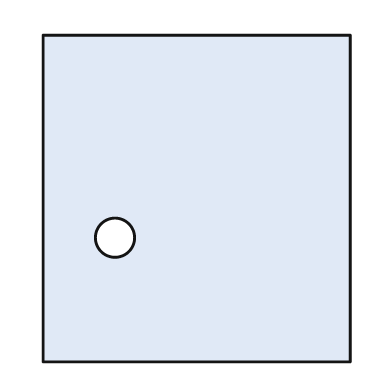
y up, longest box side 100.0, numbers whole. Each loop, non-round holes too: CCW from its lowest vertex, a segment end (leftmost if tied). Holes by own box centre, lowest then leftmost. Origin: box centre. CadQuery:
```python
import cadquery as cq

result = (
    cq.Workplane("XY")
    .moveTo(-47.0, -50.0)
    .lineTo(47.0, -50.0)
    .lineTo(47.0, 50.0)
    .lineTo(-47.0, 50.0)
    .close()
    .moveTo(-25.0, -12.0)
    .circle(6.0)
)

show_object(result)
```